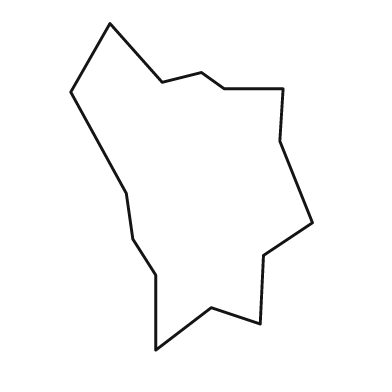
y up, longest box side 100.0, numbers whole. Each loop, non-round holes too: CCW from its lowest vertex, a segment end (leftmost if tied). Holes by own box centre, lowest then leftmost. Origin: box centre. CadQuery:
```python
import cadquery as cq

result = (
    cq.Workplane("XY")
    .moveTo(-11.0, -50.0)
    .lineTo(6.0, -37.0)
    .lineTo(21.0, -42.0)
    .lineTo(22.0, -21.0)
    .lineTo(37.0, -11.0)
    .lineTo(27.0, 14.0)
    .lineTo(28.0, 30.0)
    .lineTo(10.0, 30.0)
    .lineTo(3.0, 35.0)
    .lineTo(-9.0, 32.0)
    .lineTo(-25.0, 50.0)
    .lineTo(-37.0, 29.0)
    .lineTo(-20.0, -2.0)
    .lineTo(-18.0, -16.0)
    .lineTo(-11.0, -27.0)
    .close()
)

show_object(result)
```